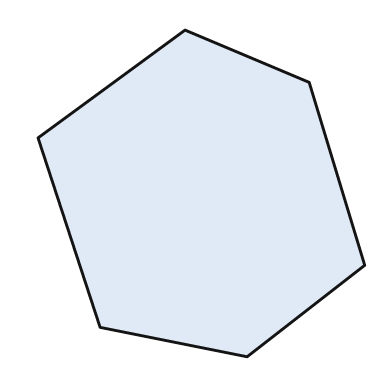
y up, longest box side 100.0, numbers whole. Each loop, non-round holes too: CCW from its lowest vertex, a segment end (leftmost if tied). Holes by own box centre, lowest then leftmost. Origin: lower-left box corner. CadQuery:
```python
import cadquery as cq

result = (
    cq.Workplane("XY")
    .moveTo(64.0, 0.0)
    .lineTo(100.0, 28.0)
    .lineTo(83.0, 84.0)
    .lineTo(45.0, 100.0)
    .lineTo(0.0, 67.0)
    .lineTo(19.0, 9.0)
    .close()
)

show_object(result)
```